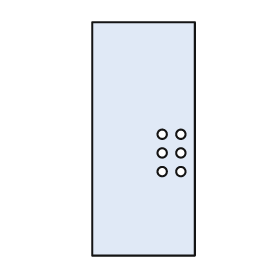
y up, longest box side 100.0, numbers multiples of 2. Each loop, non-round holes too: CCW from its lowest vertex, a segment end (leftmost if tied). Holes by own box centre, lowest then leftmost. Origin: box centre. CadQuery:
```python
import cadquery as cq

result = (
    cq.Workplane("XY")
    .moveTo(-22.0, -50.0)
    .lineTo(22.0, -50.0)
    .lineTo(22.0, 50.0)
    .lineTo(-22.0, 50.0)
    .close()
    .moveTo(8.0, -14.0)
    .circle(2.0)
    .moveTo(16.0, -14.0)
    .circle(2.0)
    .moveTo(8.0, -6.0)
    .circle(2.0)
    .moveTo(16.0, -6.0)
    .circle(2.0)
    .moveTo(8.0, 2.0)
    .circle(2.0)
    .moveTo(16.0, 2.0)
    .circle(2.0)
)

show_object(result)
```